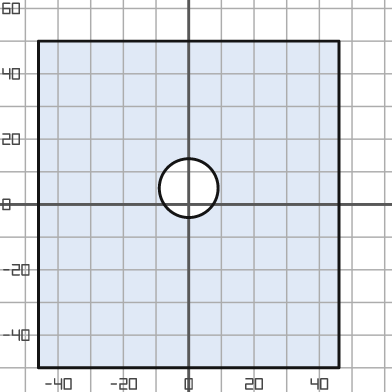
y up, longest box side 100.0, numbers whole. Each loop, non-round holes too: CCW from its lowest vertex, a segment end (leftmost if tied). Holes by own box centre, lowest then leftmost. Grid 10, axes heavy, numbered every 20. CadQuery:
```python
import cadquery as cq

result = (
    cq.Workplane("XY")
    .moveTo(-46.0, -50.0)
    .lineTo(46.0, -50.0)
    .lineTo(46.0, 50.0)
    .lineTo(-46.0, 50.0)
    .close()
    .moveTo(0.0, 5.0)
    .circle(9.0)
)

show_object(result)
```